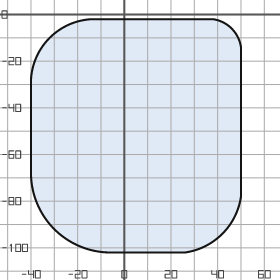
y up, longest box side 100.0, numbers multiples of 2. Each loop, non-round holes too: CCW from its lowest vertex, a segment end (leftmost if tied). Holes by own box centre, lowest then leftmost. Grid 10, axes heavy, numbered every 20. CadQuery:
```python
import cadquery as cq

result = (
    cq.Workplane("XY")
    .moveTo(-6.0, -102.0)
    .lineTo(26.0, -102.0)
    .threePointArc((42.0, -94.0), (50.0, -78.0))
    .lineTo(50.0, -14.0)
    .threePointArc((46.0, -6.0), (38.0, -2.0))
    .lineTo(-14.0, -2.0)
    .threePointArc((-32.0, -10.0), (-40.0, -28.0))
    .lineTo(-40.0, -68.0)
    .threePointArc((-30.0, -92.0), (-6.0, -102.0))
    .close()
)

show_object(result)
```